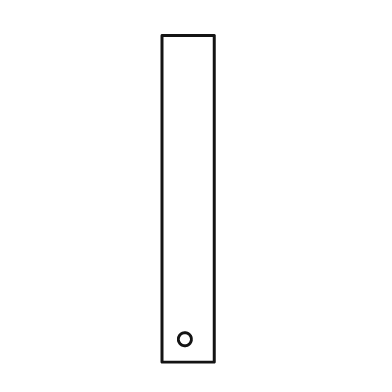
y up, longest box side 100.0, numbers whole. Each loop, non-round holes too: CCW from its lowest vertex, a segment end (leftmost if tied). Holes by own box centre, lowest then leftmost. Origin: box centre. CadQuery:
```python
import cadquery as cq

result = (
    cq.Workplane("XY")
    .moveTo(-8.0, -50.0)
    .lineTo(8.0, -50.0)
    .lineTo(8.0, 50.0)
    .lineTo(-8.0, 50.0)
    .close()
    .moveTo(-1.0, -43.0)
    .circle(2.0)
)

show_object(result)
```